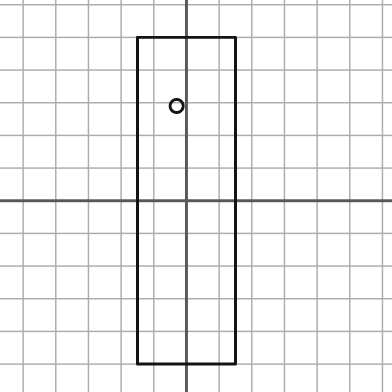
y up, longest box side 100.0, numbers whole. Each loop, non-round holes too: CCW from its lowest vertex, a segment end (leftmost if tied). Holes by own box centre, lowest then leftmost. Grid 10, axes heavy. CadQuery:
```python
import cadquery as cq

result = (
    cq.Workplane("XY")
    .moveTo(-15.0, -50.0)
    .lineTo(15.0, -50.0)
    .lineTo(15.0, 50.0)
    .lineTo(-15.0, 50.0)
    .close()
    .moveTo(-3.0, 29.0)
    .circle(2.0)
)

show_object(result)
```